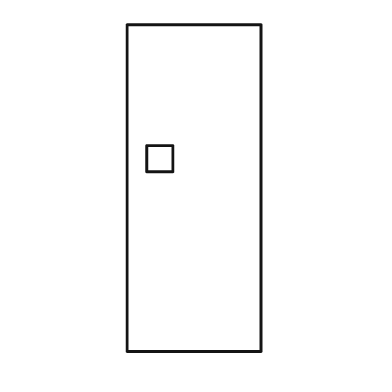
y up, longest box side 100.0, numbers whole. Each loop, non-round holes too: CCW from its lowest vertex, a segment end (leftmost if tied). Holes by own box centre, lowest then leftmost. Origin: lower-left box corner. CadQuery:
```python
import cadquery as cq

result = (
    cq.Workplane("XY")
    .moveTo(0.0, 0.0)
    .lineTo(41.0, 0.0)
    .lineTo(41.0, 100.0)
    .lineTo(0.0, 100.0)
    .close()
    .moveTo(6.0, 55.0)
    .lineTo(14.0, 55.0)
    .lineTo(14.0, 63.0)
    .lineTo(6.0, 63.0)
    .close()
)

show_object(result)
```